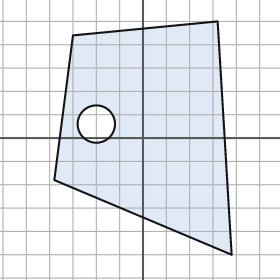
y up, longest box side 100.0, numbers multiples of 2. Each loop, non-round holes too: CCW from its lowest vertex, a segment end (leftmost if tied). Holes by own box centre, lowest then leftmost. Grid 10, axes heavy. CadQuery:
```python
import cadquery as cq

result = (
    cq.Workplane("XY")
    .moveTo(38.0, -50.0)
    .lineTo(32.0, 50.0)
    .lineTo(-30.0, 44.0)
    .lineTo(-38.0, -18.0)
    .close()
    .moveTo(-20.0, 6.0)
    .circle(8.0)
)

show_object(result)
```